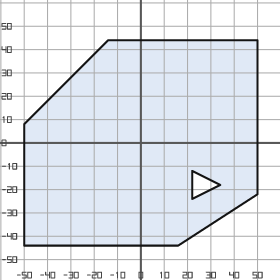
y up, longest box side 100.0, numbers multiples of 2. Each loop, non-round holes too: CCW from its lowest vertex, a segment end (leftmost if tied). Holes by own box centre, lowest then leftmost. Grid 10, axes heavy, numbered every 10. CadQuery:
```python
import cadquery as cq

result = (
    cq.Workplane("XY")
    .moveTo(-50.0, -44.0)
    .lineTo(16.0, -44.0)
    .lineTo(50.0, -22.0)
    .lineTo(50.0, 44.0)
    .lineTo(-14.0, 44.0)
    .lineTo(-50.0, 8.0)
    .close()
    .moveTo(22.0, -24.0)
    .lineTo(34.0, -18.0)
    .lineTo(22.0, -12.0)
    .close()
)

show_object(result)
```